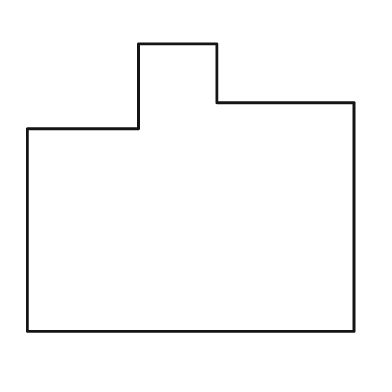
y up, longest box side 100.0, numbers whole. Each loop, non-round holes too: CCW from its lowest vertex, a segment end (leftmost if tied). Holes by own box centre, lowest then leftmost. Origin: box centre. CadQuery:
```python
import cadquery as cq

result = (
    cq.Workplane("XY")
    .moveTo(-50.0, -44.0)
    .lineTo(50.0, -44.0)
    .lineTo(50.0, 26.0)
    .lineTo(8.0, 26.0)
    .lineTo(8.0, 44.0)
    .lineTo(-16.0, 44.0)
    .lineTo(-16.0, 18.0)
    .lineTo(-50.0, 18.0)
    .close()
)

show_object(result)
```